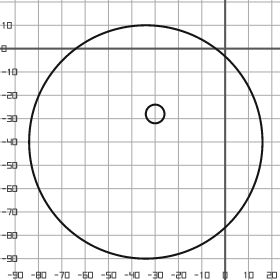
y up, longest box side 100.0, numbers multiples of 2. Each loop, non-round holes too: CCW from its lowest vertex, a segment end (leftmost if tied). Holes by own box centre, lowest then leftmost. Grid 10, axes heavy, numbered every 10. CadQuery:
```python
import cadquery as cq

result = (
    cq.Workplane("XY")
    .moveTo(-34.0, -40.0)
    .circle(50.0)
    .moveTo(-30.0, -28.0)
    .circle(4.0)
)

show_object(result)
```